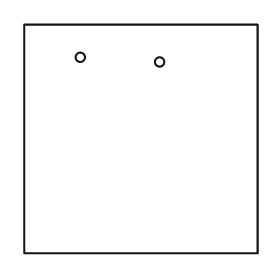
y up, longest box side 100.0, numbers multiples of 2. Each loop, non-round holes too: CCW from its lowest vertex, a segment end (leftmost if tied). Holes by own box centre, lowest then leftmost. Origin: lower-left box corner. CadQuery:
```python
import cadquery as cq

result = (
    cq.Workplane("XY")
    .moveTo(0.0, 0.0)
    .lineTo(100.0, 0.0)
    .lineTo(100.0, 98.0)
    .lineTo(0.0, 98.0)
    .close()
    .moveTo(58.0, 82.0)
    .circle(2.0)
    .moveTo(24.0, 84.0)
    .circle(2.0)
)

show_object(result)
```